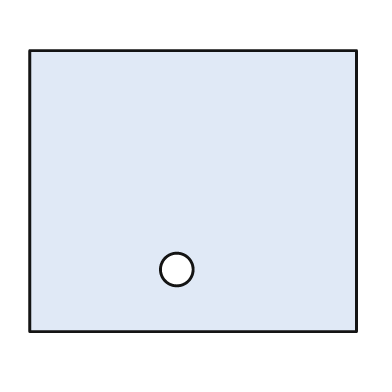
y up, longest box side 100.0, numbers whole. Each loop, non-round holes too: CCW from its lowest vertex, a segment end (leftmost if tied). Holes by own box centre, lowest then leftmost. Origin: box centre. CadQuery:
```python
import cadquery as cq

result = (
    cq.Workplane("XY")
    .moveTo(-50.0, -43.0)
    .lineTo(50.0, -43.0)
    .lineTo(50.0, 43.0)
    .lineTo(-50.0, 43.0)
    .close()
    .moveTo(-5.0, -24.0)
    .circle(5.0)
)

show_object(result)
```